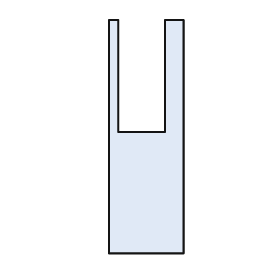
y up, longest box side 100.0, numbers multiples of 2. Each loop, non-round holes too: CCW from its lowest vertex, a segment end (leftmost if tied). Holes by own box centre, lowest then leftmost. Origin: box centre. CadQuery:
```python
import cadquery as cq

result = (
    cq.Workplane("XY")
    .moveTo(-16.0, -50.0)
    .lineTo(16.0, -50.0)
    .lineTo(16.0, 50.0)
    .lineTo(8.0, 50.0)
    .lineTo(8.0, 2.0)
    .lineTo(-12.0, 2.0)
    .lineTo(-12.0, 50.0)
    .lineTo(-16.0, 50.0)
    .close()
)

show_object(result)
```